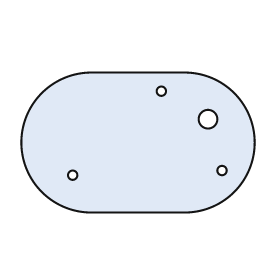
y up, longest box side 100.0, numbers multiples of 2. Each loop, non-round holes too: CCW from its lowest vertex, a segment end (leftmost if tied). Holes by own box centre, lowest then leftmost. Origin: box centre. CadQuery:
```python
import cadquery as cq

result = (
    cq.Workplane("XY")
    .moveTo(-20.0, -30.0)
    .lineTo(20.0, -30.0)
    .threePointArc((50.0, 0.0), (20.0, 30.0))
    .lineTo(-20.0, 30.0)
    .threePointArc((-50.0, 0.0), (-20.0, -30.0))
    .close()
    .moveTo(-28.0, -14.0)
    .circle(2.0)
    .moveTo(36.0, -12.0)
    .circle(2.0)
    .moveTo(30.0, 10.0)
    .circle(4.0)
    .moveTo(10.0, 22.0)
    .circle(2.0)
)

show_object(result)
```